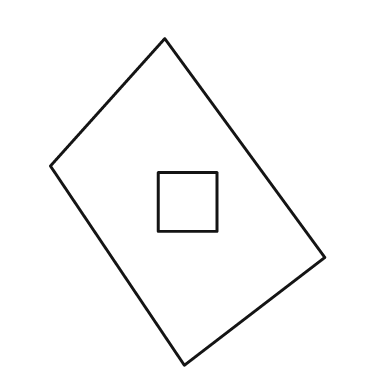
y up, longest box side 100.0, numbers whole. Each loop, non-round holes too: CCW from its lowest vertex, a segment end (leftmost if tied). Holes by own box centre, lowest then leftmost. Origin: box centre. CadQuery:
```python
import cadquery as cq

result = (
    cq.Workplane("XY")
    .moveTo(-1.0, -50.0)
    .lineTo(42.0, -17.0)
    .lineTo(-7.0, 50.0)
    .lineTo(-42.0, 11.0)
    .close()
    .moveTo(-9.0, -9.0)
    .lineTo(9.0, -9.0)
    .lineTo(9.0, 9.0)
    .lineTo(-9.0, 9.0)
    .close()
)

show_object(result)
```